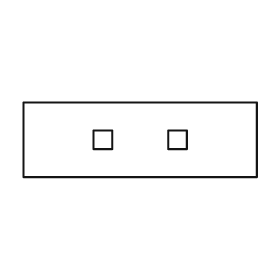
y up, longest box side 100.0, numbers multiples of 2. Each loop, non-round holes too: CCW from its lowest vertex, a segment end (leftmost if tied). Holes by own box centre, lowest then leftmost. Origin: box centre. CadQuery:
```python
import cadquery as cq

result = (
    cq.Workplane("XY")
    .moveTo(-50.0, -16.0)
    .lineTo(50.0, -16.0)
    .lineTo(50.0, 16.0)
    .lineTo(-50.0, 16.0)
    .close()
    .moveTo(-20.0, -4.0)
    .lineTo(-12.0, -4.0)
    .lineTo(-12.0, 4.0)
    .lineTo(-20.0, 4.0)
    .close()
    .moveTo(12.0, -4.0)
    .lineTo(20.0, -4.0)
    .lineTo(20.0, 4.0)
    .lineTo(12.0, 4.0)
    .close()
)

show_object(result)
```